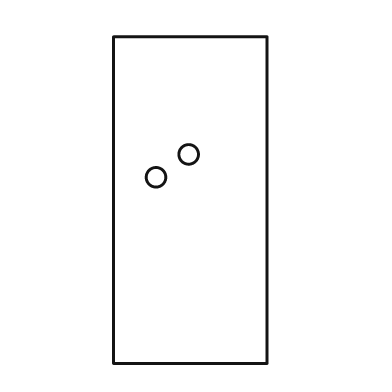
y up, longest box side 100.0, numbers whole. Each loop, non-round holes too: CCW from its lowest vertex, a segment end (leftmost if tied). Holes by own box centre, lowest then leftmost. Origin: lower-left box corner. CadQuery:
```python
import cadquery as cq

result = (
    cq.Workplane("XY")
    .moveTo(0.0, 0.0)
    .lineTo(47.0, 0.0)
    .lineTo(47.0, 100.0)
    .lineTo(0.0, 100.0)
    .close()
    .moveTo(13.0, 57.0)
    .circle(3.0)
    .moveTo(23.0, 64.0)
    .circle(3.0)
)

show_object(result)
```